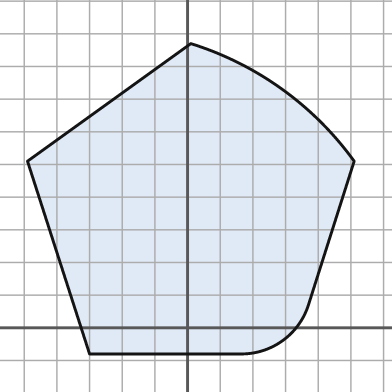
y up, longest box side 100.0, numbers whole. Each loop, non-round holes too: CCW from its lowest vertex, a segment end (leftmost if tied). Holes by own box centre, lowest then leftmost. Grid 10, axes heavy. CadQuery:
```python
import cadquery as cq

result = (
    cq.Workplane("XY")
    .moveTo(-30.0, -8.0)
    .lineTo(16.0, -8.0)
    .threePointArc((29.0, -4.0), (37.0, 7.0))
    .lineTo(51.0, 51.0)
    .threePointArc((29.0, 73.0), (1.0, 87.0))
    .lineTo(-49.0, 51.0)
    .close()
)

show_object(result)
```